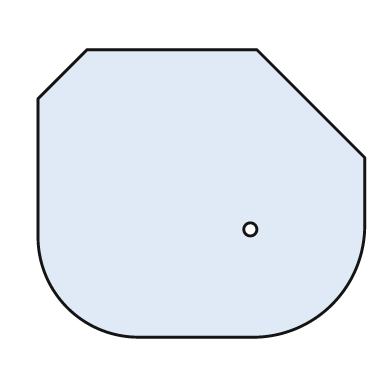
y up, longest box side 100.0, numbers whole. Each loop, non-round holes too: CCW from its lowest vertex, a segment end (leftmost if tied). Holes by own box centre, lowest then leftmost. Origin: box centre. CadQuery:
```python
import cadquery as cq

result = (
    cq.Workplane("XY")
    .moveTo(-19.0, -44.0)
    .lineTo(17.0, -44.0)
    .threePointArc((40.0, -34.0), (50.0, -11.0))
    .lineTo(50.0, 11.0)
    .lineTo(17.0, 44.0)
    .lineTo(-35.0, 44.0)
    .lineTo(-50.0, 29.0)
    .lineTo(-50.0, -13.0)
    .threePointArc((-41.0, -35.0), (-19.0, -44.0))
    .close()
    .moveTo(15.0, -11.0)
    .circle(2.0)
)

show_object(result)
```